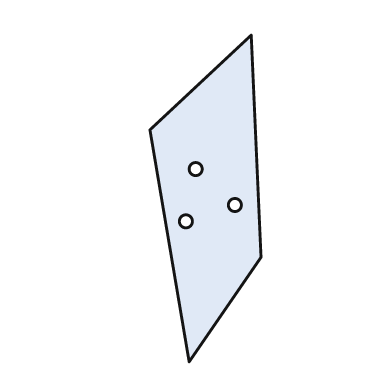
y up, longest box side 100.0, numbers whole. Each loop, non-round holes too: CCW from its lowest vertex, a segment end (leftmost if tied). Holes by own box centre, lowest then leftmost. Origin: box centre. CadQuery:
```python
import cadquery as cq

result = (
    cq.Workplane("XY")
    .moveTo(-5.0, -50.0)
    .lineTo(17.0, -18.0)
    .lineTo(14.0, 50.0)
    .lineTo(-17.0, 21.0)
    .close()
    .moveTo(-6.0, -7.0)
    .circle(2.0)
    .moveTo(9.0, -2.0)
    .circle(2.0)
    .moveTo(-3.0, 9.0)
    .circle(2.0)
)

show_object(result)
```